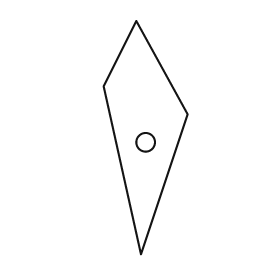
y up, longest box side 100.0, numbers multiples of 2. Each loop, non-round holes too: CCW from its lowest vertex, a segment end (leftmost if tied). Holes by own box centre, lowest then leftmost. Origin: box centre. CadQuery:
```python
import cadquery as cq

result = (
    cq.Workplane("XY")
    .moveTo(-2.0, -50.0)
    .lineTo(18.0, 10.0)
    .lineTo(-4.0, 50.0)
    .lineTo(-18.0, 22.0)
    .close()
    .moveTo(0.0, -2.0)
    .circle(4.0)
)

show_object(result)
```